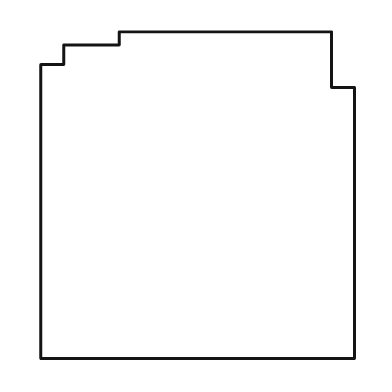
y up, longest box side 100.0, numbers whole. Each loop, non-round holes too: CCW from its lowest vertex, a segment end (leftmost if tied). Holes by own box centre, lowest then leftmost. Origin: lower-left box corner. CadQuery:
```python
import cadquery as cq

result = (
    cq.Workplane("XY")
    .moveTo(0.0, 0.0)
    .lineTo(96.0, 0.0)
    .lineTo(96.0, 83.0)
    .lineTo(89.0, 83.0)
    .lineTo(89.0, 100.0)
    .lineTo(24.0, 100.0)
    .lineTo(24.0, 96.0)
    .lineTo(7.0, 96.0)
    .lineTo(7.0, 90.0)
    .lineTo(0.0, 90.0)
    .close()
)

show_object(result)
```